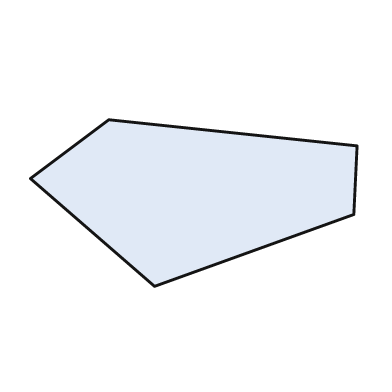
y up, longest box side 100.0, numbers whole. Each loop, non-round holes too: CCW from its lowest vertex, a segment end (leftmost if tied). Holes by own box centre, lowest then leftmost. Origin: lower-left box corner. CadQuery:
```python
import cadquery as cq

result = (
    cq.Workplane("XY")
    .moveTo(38.0, 0.0)
    .lineTo(99.0, 22.0)
    .lineTo(100.0, 43.0)
    .lineTo(24.0, 51.0)
    .lineTo(0.0, 33.0)
    .close()
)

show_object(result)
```